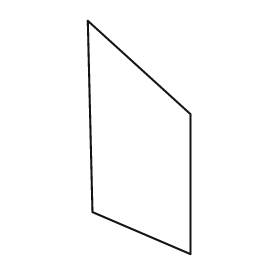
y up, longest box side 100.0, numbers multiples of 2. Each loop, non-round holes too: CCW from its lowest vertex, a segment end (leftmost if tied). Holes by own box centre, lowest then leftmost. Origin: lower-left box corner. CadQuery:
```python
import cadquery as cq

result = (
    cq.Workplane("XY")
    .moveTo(44.0, 0.0)
    .lineTo(44.0, 60.0)
    .lineTo(0.0, 100.0)
    .lineTo(2.0, 18.0)
    .close()
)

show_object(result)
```